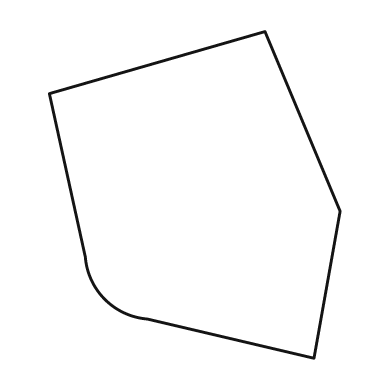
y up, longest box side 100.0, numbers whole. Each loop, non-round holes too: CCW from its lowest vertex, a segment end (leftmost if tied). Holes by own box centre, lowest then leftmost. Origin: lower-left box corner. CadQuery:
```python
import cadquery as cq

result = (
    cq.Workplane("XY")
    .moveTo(81.0, 0.0)
    .lineTo(89.0, 45.0)
    .lineTo(66.0, 100.0)
    .lineTo(0.0, 81.0)
    .lineTo(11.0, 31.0)
    .threePointArc((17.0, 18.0), (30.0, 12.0))
    .close()
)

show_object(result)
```